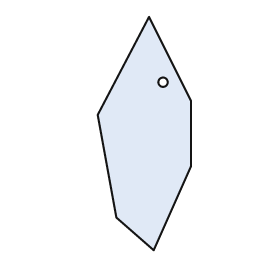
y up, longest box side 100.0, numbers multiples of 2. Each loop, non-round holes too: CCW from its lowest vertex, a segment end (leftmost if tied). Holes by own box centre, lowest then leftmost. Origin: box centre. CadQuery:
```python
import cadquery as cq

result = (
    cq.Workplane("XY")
    .moveTo(4.0, -50.0)
    .lineTo(20.0, -14.0)
    .lineTo(20.0, 14.0)
    .lineTo(2.0, 50.0)
    .lineTo(-20.0, 8.0)
    .lineTo(-12.0, -36.0)
    .close()
    .moveTo(8.0, 22.0)
    .circle(2.0)
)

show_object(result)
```